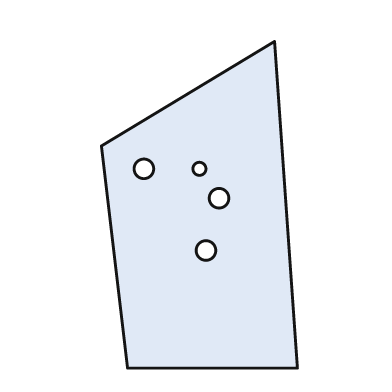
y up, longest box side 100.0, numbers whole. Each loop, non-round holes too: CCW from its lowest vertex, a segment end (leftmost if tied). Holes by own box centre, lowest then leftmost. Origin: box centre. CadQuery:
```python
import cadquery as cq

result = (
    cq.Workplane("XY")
    .moveTo(-22.0, -50.0)
    .lineTo(30.0, -50.0)
    .lineTo(23.0, 50.0)
    .lineTo(-30.0, 18.0)
    .close()
    .moveTo(2.0, -14.0)
    .circle(3.0)
    .moveTo(6.0, 2.0)
    .circle(3.0)
    .moveTo(-17.0, 11.0)
    .circle(3.0)
    .moveTo(0.0, 11.0)
    .circle(2.0)
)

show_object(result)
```